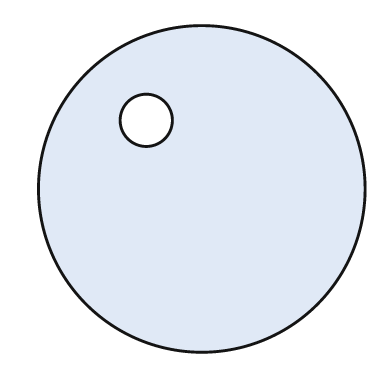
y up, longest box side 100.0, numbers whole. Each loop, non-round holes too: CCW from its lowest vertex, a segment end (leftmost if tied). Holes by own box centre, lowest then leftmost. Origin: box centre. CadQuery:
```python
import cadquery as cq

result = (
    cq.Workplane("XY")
    .moveTo(0.0, 0.0)
    .circle(50.0)
    .moveTo(-17.0, 21.0)
    .circle(8.0)
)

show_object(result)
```